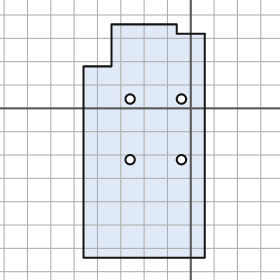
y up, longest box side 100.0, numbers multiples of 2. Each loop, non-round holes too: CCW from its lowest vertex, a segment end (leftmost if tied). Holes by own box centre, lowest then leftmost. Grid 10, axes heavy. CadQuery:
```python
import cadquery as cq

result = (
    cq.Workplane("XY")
    .moveTo(-46.0, -64.0)
    .lineTo(6.0, -64.0)
    .lineTo(6.0, 32.0)
    .lineTo(-6.0, 32.0)
    .lineTo(-6.0, 36.0)
    .lineTo(-34.0, 36.0)
    .lineTo(-34.0, 18.0)
    .lineTo(-46.0, 18.0)
    .close()
    .moveTo(-26.0, -22.0)
    .circle(2.0)
    .moveTo(-4.0, -22.0)
    .circle(2.0)
    .moveTo(-26.0, 4.0)
    .circle(2.0)
    .moveTo(-4.0, 4.0)
    .circle(2.0)
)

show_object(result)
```